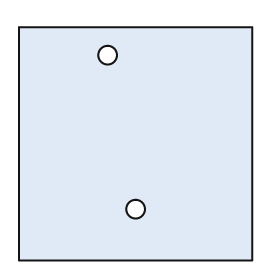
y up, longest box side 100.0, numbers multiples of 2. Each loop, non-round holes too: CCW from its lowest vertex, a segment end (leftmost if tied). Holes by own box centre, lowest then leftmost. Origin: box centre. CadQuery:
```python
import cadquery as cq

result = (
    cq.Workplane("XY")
    .moveTo(-50.0, -50.0)
    .lineTo(50.0, -50.0)
    .lineTo(50.0, 50.0)
    .lineTo(-50.0, 50.0)
    .close()
    .moveTo(0.0, -28.0)
    .circle(4.0)
    .moveTo(-12.0, 38.0)
    .circle(4.0)
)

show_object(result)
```